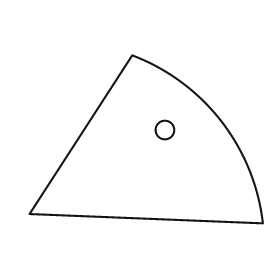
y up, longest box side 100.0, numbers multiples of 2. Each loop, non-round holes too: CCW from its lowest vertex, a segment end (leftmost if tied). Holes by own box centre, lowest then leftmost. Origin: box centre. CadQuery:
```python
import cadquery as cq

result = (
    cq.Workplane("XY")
    .moveTo(50.0, -36.0)
    .threePointArc((32.0, 8.0), (-6.0, 36.0))
    .lineTo(-50.0, -32.0)
    .close()
    .moveTo(8.0, 4.0)
    .circle(4.0)
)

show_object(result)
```